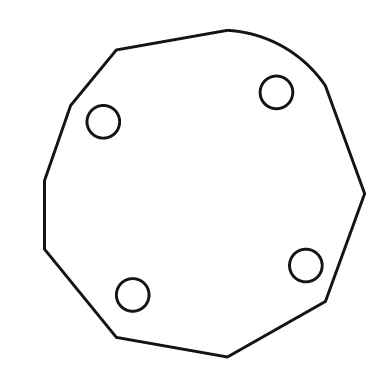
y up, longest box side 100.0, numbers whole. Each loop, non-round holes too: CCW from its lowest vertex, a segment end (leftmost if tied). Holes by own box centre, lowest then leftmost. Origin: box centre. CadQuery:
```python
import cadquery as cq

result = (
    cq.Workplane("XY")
    .moveTo(7.0, -50.0)
    .lineTo(37.0, -33.0)
    .lineTo(49.0, 0.0)
    .lineTo(37.0, 33.0)
    .threePointArc((24.0, 45.0), (7.0, 50.0))
    .lineTo(-27.0, 44.0)
    .lineTo(-41.0, 27.0)
    .lineTo(-49.0, 4.0)
    .lineTo(-49.0, -17.0)
    .lineTo(-27.0, -44.0)
    .close()
    .moveTo(-22.0, -31.0)
    .circle(5.0)
    .moveTo(31.0, -22.0)
    .circle(5.0)
    .moveTo(-31.0, 22.0)
    .circle(5.0)
    .moveTo(22.0, 31.0)
    .circle(5.0)
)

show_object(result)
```